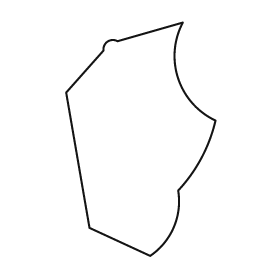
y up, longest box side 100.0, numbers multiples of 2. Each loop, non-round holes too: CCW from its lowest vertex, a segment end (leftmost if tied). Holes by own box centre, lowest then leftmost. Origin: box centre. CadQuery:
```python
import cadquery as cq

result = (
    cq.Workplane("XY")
    .moveTo(4.0, -50.0)
    .threePointArc((14.0, -38.0), (16.0, -22.0))
    .threePointArc((26.0, -8.0), (32.0, 8.0))
    .threePointArc((16.0, 26.0), (18.0, 50.0))
    .lineTo(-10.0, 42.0)
    .threePointArc((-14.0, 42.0), (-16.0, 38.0))
    .lineTo(-32.0, 20.0)
    .lineTo(-22.0, -38.0)
    .close()
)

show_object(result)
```